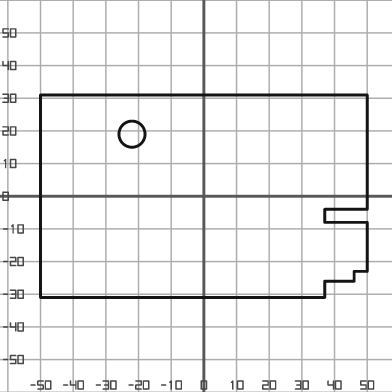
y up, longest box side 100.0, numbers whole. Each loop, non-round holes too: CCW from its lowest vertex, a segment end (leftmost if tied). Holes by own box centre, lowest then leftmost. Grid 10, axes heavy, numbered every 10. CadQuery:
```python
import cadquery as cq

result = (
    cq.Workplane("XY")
    .moveTo(-50.0, -31.0)
    .lineTo(37.0, -31.0)
    .lineTo(37.0, -26.0)
    .lineTo(46.0, -26.0)
    .lineTo(46.0, -23.0)
    .lineTo(50.0, -23.0)
    .lineTo(50.0, -8.0)
    .lineTo(37.0, -8.0)
    .lineTo(37.0, -4.0)
    .lineTo(50.0, -4.0)
    .lineTo(50.0, 31.0)
    .lineTo(-50.0, 31.0)
    .close()
    .moveTo(-22.0, 19.0)
    .circle(4.0)
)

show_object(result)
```